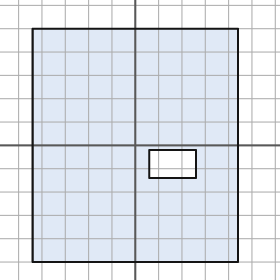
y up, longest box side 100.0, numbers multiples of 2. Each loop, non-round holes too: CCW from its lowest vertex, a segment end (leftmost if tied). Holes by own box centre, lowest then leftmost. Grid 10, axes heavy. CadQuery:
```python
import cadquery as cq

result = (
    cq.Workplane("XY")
    .moveTo(-44.0, -50.0)
    .lineTo(44.0, -50.0)
    .lineTo(44.0, 50.0)
    .lineTo(-44.0, 50.0)
    .close()
    .moveTo(6.0, -14.0)
    .lineTo(26.0, -14.0)
    .lineTo(26.0, -2.0)
    .lineTo(6.0, -2.0)
    .close()
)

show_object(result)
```